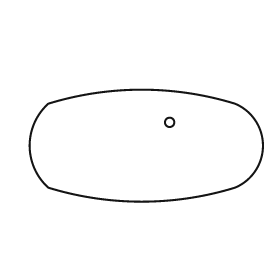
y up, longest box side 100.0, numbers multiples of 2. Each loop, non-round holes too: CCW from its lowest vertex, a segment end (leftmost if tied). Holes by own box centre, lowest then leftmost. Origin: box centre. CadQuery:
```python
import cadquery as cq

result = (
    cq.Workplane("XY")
    .moveTo(-42.0, -18.0)
    .threePointArc((-2.0, -24.0), (38.0, -18.0))
    .threePointArc((50.0, 0.0), (38.0, 18.0))
    .threePointArc((-2.0, 24.0), (-42.0, 18.0))
    .threePointArc((-50.0, 0.0), (-42.0, -18.0))
    .close()
    .moveTo(10.0, 10.0)
    .circle(2.0)
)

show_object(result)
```